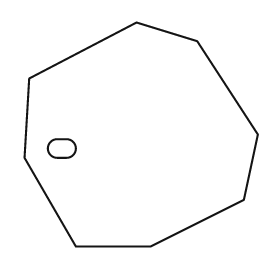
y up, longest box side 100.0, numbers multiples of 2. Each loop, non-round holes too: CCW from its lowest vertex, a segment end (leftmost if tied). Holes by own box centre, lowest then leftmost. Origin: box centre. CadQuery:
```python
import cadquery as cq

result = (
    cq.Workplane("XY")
    .moveTo(-28.0, -48.0)
    .lineTo(4.0, -48.0)
    .lineTo(44.0, -28.0)
    .lineTo(50.0, 0.0)
    .lineTo(24.0, 40.0)
    .lineTo(-2.0, 48.0)
    .lineTo(-48.0, 24.0)
    .lineTo(-50.0, -10.0)
    .close()
    .moveTo(-36.0, -10.0)
    .lineTo(-32.0, -10.0)
    .threePointArc((-28.0, -6.0), (-32.0, -2.0))
    .lineTo(-36.0, -2.0)
    .threePointArc((-40.0, -6.0), (-36.0, -10.0))
    .close()
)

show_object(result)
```